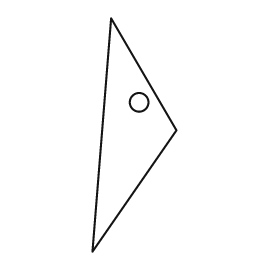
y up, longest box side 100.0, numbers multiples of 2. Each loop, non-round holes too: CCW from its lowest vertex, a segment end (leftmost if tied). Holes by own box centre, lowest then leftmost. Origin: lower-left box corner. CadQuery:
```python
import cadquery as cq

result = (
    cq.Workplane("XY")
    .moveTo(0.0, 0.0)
    .lineTo(36.0, 52.0)
    .lineTo(8.0, 100.0)
    .close()
    .moveTo(20.0, 64.0)
    .circle(4.0)
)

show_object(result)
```